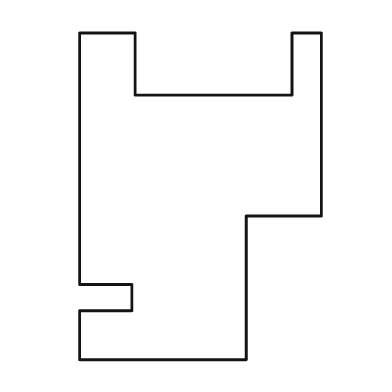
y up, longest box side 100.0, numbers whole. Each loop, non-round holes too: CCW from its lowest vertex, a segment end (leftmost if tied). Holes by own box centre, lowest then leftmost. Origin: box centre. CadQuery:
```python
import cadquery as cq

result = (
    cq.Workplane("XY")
    .moveTo(-37.0, -50.0)
    .lineTo(14.0, -50.0)
    .lineTo(14.0, -6.0)
    .lineTo(37.0, -6.0)
    .lineTo(37.0, 50.0)
    .lineTo(28.0, 50.0)
    .lineTo(28.0, 31.0)
    .lineTo(-20.0, 31.0)
    .lineTo(-20.0, 50.0)
    .lineTo(-37.0, 50.0)
    .lineTo(-37.0, -27.0)
    .lineTo(-21.0, -27.0)
    .lineTo(-21.0, -35.0)
    .lineTo(-37.0, -35.0)
    .close()
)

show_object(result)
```